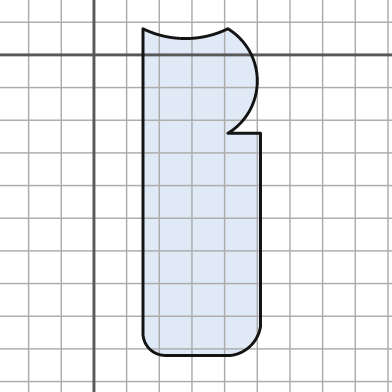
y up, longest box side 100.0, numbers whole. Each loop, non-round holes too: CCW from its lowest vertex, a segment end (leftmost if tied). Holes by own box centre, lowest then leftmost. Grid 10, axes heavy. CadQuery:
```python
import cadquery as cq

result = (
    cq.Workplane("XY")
    .moveTo(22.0, -92.0)
    .lineTo(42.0, -92.0)
    .threePointArc((48.0, -89.0), (51.0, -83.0))
    .lineTo(51.0, -24.0)
    .lineTo(41.0, -24.0)
    .threePointArc((50.0, -8.0), (41.0, 8.0))
    .threePointArc((28.0, 5.0), (15.0, 8.0))
    .lineTo(15.0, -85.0)
    .threePointArc((17.0, -90.0), (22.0, -92.0))
    .close()
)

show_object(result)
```